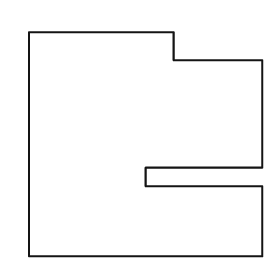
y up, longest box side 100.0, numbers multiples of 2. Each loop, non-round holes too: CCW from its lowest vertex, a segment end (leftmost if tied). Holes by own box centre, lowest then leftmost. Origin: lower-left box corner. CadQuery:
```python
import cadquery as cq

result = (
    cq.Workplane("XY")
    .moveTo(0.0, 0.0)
    .lineTo(100.0, 0.0)
    .lineTo(100.0, 30.0)
    .lineTo(50.0, 30.0)
    .lineTo(50.0, 38.0)
    .lineTo(100.0, 38.0)
    .lineTo(100.0, 84.0)
    .lineTo(62.0, 84.0)
    .lineTo(62.0, 96.0)
    .lineTo(0.0, 96.0)
    .close()
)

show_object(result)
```